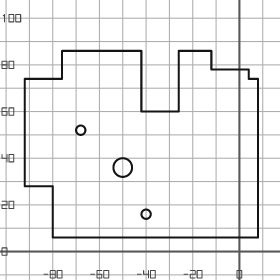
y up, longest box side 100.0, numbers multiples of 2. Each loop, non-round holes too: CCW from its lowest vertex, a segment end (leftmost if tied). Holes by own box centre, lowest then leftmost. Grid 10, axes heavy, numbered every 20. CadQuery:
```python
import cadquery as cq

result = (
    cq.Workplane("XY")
    .moveTo(-80.0, 6.0)
    .lineTo(8.0, 6.0)
    .lineTo(8.0, 74.0)
    .lineTo(4.0, 74.0)
    .lineTo(4.0, 78.0)
    .lineTo(-12.0, 78.0)
    .lineTo(-12.0, 86.0)
    .lineTo(-26.0, 86.0)
    .lineTo(-26.0, 60.0)
    .lineTo(-42.0, 60.0)
    .lineTo(-42.0, 86.0)
    .lineTo(-76.0, 86.0)
    .lineTo(-76.0, 74.0)
    .lineTo(-92.0, 74.0)
    .lineTo(-92.0, 28.0)
    .lineTo(-80.0, 28.0)
    .close()
    .moveTo(-40.0, 16.0)
    .circle(2.0)
    .moveTo(-50.0, 36.0)
    .circle(4.0)
    .moveTo(-68.0, 52.0)
    .circle(2.0)
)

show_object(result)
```